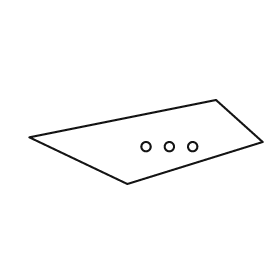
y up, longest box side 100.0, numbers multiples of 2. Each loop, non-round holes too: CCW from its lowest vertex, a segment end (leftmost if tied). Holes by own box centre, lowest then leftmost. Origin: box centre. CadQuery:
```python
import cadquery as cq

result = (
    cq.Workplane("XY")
    .moveTo(-8.0, -18.0)
    .lineTo(50.0, 0.0)
    .lineTo(30.0, 18.0)
    .lineTo(-50.0, 2.0)
    .close()
    .moveTo(0.0, -2.0)
    .circle(2.0)
    .moveTo(10.0, -2.0)
    .circle(2.0)
    .moveTo(20.0, -2.0)
    .circle(2.0)
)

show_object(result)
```